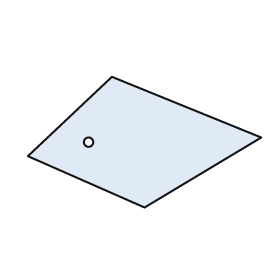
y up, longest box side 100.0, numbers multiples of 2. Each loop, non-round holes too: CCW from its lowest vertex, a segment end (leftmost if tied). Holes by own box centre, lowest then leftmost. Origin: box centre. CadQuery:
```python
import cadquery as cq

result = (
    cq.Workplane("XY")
    .moveTo(0.0, -28.0)
    .lineTo(50.0, 2.0)
    .lineTo(-14.0, 28.0)
    .lineTo(-50.0, -6.0)
    .close()
    .moveTo(-24.0, 0.0)
    .circle(2.0)
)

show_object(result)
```